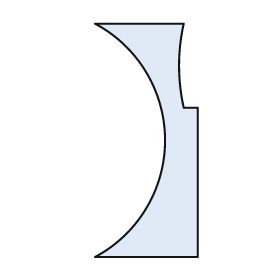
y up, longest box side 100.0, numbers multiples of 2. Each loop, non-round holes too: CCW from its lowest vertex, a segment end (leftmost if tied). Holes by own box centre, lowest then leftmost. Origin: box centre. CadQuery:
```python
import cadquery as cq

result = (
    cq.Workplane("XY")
    .moveTo(-22.0, -50.0)
    .lineTo(22.0, -50.0)
    .lineTo(22.0, 14.0)
    .lineTo(16.0, 14.0)
    .threePointArc((14.0, 32.0), (16.0, 50.0))
    .lineTo(-22.0, 50.0)
    .threePointArc((8.0, 0.0), (-22.0, -50.0))
    .close()
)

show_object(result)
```